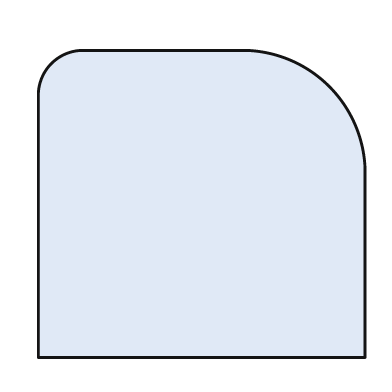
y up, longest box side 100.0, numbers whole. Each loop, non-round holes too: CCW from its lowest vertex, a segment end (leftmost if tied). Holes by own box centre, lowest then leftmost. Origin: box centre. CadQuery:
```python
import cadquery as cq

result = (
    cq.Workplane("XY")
    .moveTo(-50.0, -47.0)
    .lineTo(50.0, -47.0)
    .lineTo(50.0, 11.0)
    .threePointArc((39.0, 36.0), (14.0, 47.0))
    .lineTo(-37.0, 47.0)
    .threePointArc((-46.0, 43.0), (-50.0, 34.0))
    .close()
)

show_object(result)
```